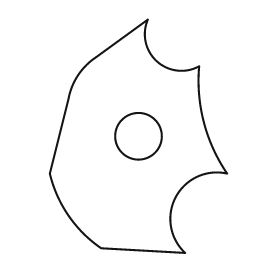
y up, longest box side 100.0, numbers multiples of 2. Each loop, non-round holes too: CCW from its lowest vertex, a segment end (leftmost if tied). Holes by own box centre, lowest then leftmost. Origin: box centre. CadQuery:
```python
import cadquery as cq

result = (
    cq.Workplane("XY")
    .moveTo(20.0, -50.0)
    .threePointArc((16.0, -26.0), (38.0, -16.0))
    .threePointArc((28.0, 6.0), (26.0, 30.0))
    .threePointArc((8.0, 32.0), (4.0, 50.0))
    .lineTo(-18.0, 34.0)
    .threePointArc((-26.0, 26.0), (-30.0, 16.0))
    .lineTo(-38.0, -16.0)
    .threePointArc((-30.0, -34.0), (-16.0, -48.0))
    .close()
    .moveTo(0.0, 0.0)
    .circle(10.0)
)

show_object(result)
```